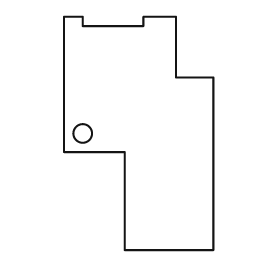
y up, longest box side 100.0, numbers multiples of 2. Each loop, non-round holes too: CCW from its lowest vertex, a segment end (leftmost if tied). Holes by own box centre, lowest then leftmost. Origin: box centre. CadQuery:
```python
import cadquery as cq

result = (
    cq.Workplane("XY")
    .moveTo(-6.0, -50.0)
    .lineTo(32.0, -50.0)
    .lineTo(32.0, 24.0)
    .lineTo(16.0, 24.0)
    .lineTo(16.0, 50.0)
    .lineTo(2.0, 50.0)
    .lineTo(2.0, 46.0)
    .lineTo(-24.0, 46.0)
    .lineTo(-24.0, 50.0)
    .lineTo(-32.0, 50.0)
    .lineTo(-32.0, -8.0)
    .lineTo(-6.0, -8.0)
    .close()
    .moveTo(-24.0, 0.0)
    .circle(4.0)
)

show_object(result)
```